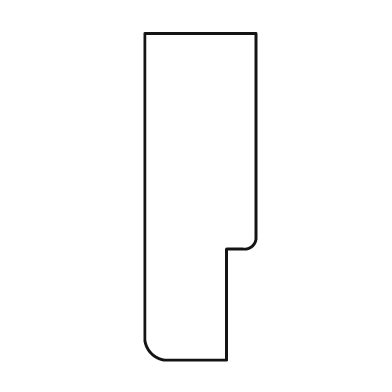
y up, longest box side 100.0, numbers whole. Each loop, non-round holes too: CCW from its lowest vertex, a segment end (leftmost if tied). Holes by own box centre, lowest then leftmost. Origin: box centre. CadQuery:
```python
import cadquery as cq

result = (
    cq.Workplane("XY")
    .moveTo(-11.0, -50.0)
    .lineTo(8.0, -50.0)
    .lineTo(8.0, -16.0)
    .lineTo(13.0, -16.0)
    .threePointArc((16.0, -15.0), (17.0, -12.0))
    .lineTo(17.0, 50.0)
    .lineTo(-17.0, 50.0)
    .lineTo(-17.0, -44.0)
    .threePointArc((-15.0, -48.0), (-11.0, -50.0))
    .close()
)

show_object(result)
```